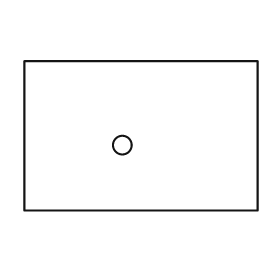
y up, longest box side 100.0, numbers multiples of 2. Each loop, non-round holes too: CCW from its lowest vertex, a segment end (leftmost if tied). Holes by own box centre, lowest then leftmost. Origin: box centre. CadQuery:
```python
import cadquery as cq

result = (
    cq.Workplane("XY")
    .moveTo(-50.0, -32.0)
    .lineTo(50.0, -32.0)
    .lineTo(50.0, 32.0)
    .lineTo(-50.0, 32.0)
    .close()
    .moveTo(-8.0, -4.0)
    .circle(4.0)
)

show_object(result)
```